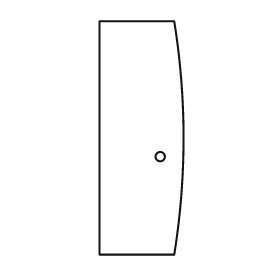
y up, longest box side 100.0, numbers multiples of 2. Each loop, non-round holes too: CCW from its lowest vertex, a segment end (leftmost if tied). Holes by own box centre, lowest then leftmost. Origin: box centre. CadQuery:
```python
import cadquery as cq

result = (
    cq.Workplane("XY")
    .moveTo(-18.0, -50.0)
    .lineTo(14.0, -50.0)
    .threePointArc((18.0, 0.0), (14.0, 50.0))
    .lineTo(-18.0, 50.0)
    .close()
    .moveTo(8.0, -8.0)
    .circle(2.0)
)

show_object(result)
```